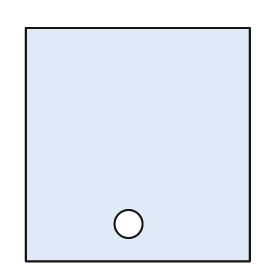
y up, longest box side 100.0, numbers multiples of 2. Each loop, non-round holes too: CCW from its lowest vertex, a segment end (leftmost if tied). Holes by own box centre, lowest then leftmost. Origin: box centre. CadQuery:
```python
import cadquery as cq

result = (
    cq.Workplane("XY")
    .moveTo(-48.0, -50.0)
    .lineTo(48.0, -50.0)
    .lineTo(48.0, 50.0)
    .lineTo(-48.0, 50.0)
    .close()
    .moveTo(-4.0, -34.0)
    .circle(6.0)
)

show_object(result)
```